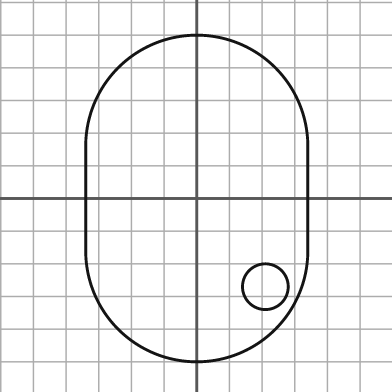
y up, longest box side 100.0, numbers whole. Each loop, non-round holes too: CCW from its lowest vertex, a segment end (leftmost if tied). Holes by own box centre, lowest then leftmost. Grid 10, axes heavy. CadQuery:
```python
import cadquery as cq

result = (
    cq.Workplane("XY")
    .moveTo(-34.0, -16.0)
    .threePointArc((0.0, -50.0), (34.0, -16.0))
    .lineTo(34.0, 16.0)
    .threePointArc((0.0, 50.0), (-34.0, 16.0))
    .close()
    .moveTo(21.0, -27.0)
    .circle(7.0)
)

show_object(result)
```